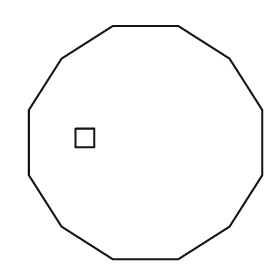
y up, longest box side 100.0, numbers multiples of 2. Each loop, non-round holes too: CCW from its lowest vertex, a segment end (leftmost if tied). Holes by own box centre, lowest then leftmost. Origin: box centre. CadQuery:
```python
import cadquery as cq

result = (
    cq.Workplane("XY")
    .moveTo(-14.0, -50.0)
    .lineTo(14.0, -50.0)
    .lineTo(36.0, -36.0)
    .lineTo(50.0, -14.0)
    .lineTo(50.0, 14.0)
    .lineTo(36.0, 36.0)
    .lineTo(14.0, 50.0)
    .lineTo(-14.0, 50.0)
    .lineTo(-36.0, 36.0)
    .lineTo(-50.0, 14.0)
    .lineTo(-50.0, -14.0)
    .lineTo(-36.0, -36.0)
    .close()
    .moveTo(-30.0, -2.0)
    .lineTo(-22.0, -2.0)
    .lineTo(-22.0, 6.0)
    .lineTo(-30.0, 6.0)
    .close()
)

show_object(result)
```